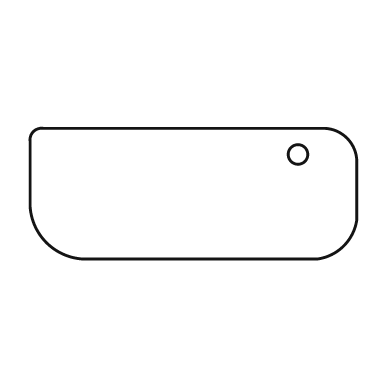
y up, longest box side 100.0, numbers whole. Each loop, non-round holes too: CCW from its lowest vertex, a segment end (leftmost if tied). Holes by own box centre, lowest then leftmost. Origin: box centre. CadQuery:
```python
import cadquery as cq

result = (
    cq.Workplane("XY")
    .moveTo(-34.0, -20.0)
    .lineTo(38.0, -20.0)
    .threePointArc((46.0, -16.0), (50.0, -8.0))
    .lineTo(50.0, 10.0)
    .threePointArc((47.0, 17.0), (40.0, 20.0))
    .lineTo(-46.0, 20.0)
    .threePointArc((-49.0, 19.0), (-50.0, 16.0))
    .lineTo(-50.0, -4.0)
    .threePointArc((-45.0, -15.0), (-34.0, -20.0))
    .close()
    .moveTo(32.0, 12.0)
    .circle(3.0)
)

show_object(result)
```